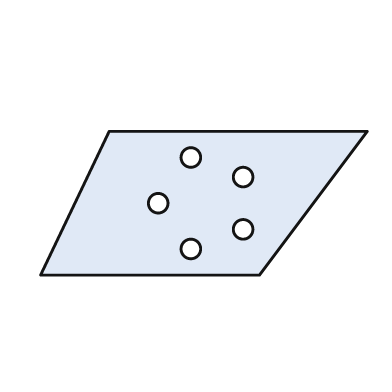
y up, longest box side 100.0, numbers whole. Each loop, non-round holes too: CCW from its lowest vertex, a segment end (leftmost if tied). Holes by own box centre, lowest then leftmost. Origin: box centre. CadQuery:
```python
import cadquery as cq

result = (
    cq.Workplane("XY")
    .moveTo(-50.0, -22.0)
    .lineTo(17.0, -22.0)
    .lineTo(50.0, 22.0)
    .lineTo(-29.0, 22.0)
    .close()
    .moveTo(-4.0, -14.0)
    .circle(3.0)
    .moveTo(12.0, -8.0)
    .circle(3.0)
    .moveTo(-14.0, 0.0)
    .circle(3.0)
    .moveTo(12.0, 8.0)
    .circle(3.0)
    .moveTo(-4.0, 14.0)
    .circle(3.0)
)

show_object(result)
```